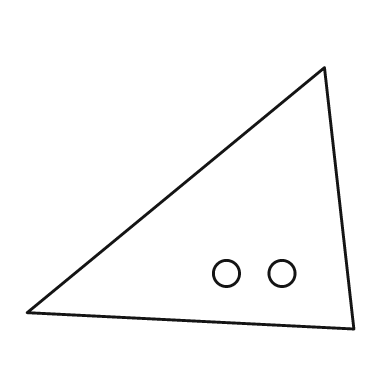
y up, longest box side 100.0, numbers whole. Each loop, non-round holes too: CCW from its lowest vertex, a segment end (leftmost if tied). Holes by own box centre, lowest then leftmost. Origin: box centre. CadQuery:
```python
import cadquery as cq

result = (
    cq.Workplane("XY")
    .moveTo(50.0, -40.0)
    .lineTo(41.0, 40.0)
    .lineTo(-50.0, -35.0)
    .close()
    .moveTo(11.0, -23.0)
    .circle(4.0)
    .moveTo(28.0, -23.0)
    .circle(4.0)
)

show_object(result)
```